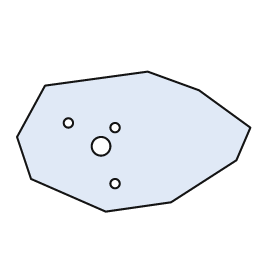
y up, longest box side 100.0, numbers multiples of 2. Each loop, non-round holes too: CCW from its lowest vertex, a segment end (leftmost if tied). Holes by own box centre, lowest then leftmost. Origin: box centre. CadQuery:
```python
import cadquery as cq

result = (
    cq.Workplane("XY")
    .moveTo(-12.0, -30.0)
    .lineTo(16.0, -26.0)
    .lineTo(44.0, -8.0)
    .lineTo(50.0, 6.0)
    .lineTo(28.0, 22.0)
    .lineTo(6.0, 30.0)
    .lineTo(-38.0, 24.0)
    .lineTo(-50.0, 2.0)
    .lineTo(-44.0, -16.0)
    .close()
    .moveTo(-8.0, -18.0)
    .circle(2.0)
    .moveTo(-14.0, -2.0)
    .circle(4.0)
    .moveTo(-8.0, 6.0)
    .circle(2.0)
    .moveTo(-28.0, 8.0)
    .circle(2.0)
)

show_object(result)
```